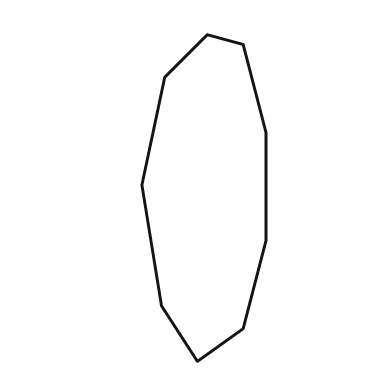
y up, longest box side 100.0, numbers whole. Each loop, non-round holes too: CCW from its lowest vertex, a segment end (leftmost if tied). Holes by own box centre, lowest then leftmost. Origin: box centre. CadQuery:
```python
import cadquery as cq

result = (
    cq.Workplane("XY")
    .moveTo(-2.0, -50.0)
    .lineTo(12.0, -40.0)
    .lineTo(19.0, -13.0)
    .lineTo(19.0, 20.0)
    .lineTo(12.0, 47.0)
    .lineTo(1.0, 50.0)
    .lineTo(-12.0, 37.0)
    .lineTo(-19.0, 4.0)
    .lineTo(-13.0, -33.0)
    .close()
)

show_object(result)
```